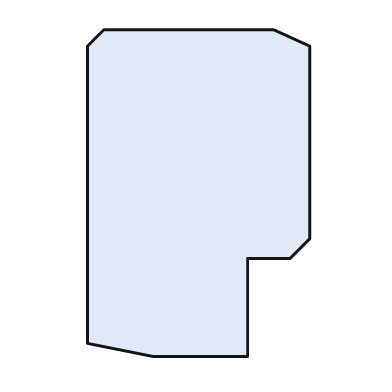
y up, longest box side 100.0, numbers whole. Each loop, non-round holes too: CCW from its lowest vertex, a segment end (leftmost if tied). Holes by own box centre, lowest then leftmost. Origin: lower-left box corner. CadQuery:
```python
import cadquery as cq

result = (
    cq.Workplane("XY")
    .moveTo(20.0, 0.0)
    .lineTo(49.0, 0.0)
    .lineTo(49.0, 30.0)
    .lineTo(62.0, 30.0)
    .lineTo(68.0, 36.0)
    .lineTo(68.0, 95.0)
    .lineTo(57.0, 100.0)
    .lineTo(5.0, 100.0)
    .lineTo(0.0, 95.0)
    .lineTo(0.0, 4.0)
    .close()
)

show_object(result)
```